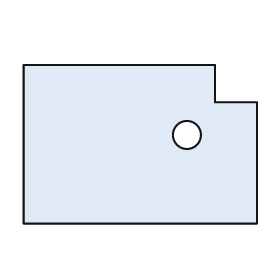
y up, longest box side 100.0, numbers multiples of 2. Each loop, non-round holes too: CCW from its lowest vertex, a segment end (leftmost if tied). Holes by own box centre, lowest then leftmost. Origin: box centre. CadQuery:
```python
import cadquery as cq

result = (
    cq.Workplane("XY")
    .moveTo(-50.0, -34.0)
    .lineTo(50.0, -34.0)
    .lineTo(50.0, 18.0)
    .lineTo(32.0, 18.0)
    .lineTo(32.0, 34.0)
    .lineTo(-50.0, 34.0)
    .close()
    .moveTo(20.0, 4.0)
    .circle(6.0)
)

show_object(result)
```